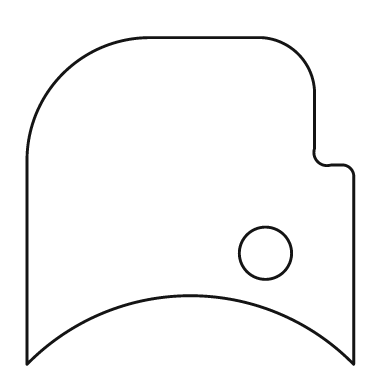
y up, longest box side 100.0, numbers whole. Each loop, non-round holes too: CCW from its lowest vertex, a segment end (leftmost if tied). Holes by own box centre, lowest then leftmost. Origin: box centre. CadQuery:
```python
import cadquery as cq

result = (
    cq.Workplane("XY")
    .moveTo(-50.0, -50.0)
    .threePointArc((0.0, -29.0), (50.0, -50.0))
    .lineTo(50.0, 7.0)
    .threePointArc((49.0, 10.0), (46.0, 11.0))
    .lineTo(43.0, 11.0)
    .threePointArc((39.0, 12.0), (38.0, 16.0))
    .lineTo(38.0, 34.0)
    .threePointArc((33.0, 45.0), (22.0, 50.0))
    .lineTo(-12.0, 50.0)
    .threePointArc((-39.0, 39.0), (-50.0, 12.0))
    .close()
    .moveTo(23.0, -16.0)
    .circle(8.0)
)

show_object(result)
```